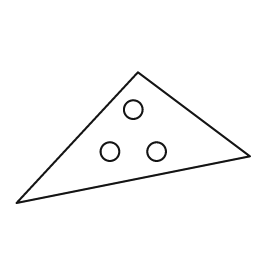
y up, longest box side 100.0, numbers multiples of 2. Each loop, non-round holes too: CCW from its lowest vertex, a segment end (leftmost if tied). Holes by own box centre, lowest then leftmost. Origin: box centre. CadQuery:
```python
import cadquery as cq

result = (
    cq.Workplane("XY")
    .moveTo(-50.0, -28.0)
    .lineTo(50.0, -8.0)
    .lineTo(2.0, 28.0)
    .close()
    .moveTo(-10.0, -6.0)
    .circle(4.0)
    .moveTo(10.0, -6.0)
    .circle(4.0)
    .moveTo(0.0, 12.0)
    .circle(4.0)
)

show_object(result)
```